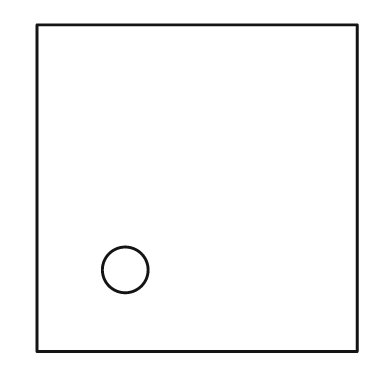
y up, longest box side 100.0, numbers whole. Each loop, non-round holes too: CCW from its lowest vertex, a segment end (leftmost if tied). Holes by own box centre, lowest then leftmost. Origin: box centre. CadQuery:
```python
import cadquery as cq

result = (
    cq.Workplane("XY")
    .moveTo(-49.0, -50.0)
    .lineTo(49.0, -50.0)
    .lineTo(49.0, 50.0)
    .lineTo(-49.0, 50.0)
    .close()
    .moveTo(-22.0, -25.0)
    .circle(7.0)
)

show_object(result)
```